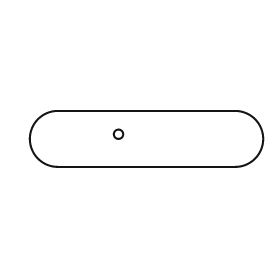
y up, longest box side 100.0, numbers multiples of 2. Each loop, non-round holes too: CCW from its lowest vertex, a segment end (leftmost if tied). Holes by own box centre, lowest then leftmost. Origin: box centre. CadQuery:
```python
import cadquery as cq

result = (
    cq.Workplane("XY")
    .moveTo(-38.0, -12.0)
    .lineTo(38.0, -12.0)
    .threePointArc((50.0, 0.0), (38.0, 12.0))
    .lineTo(-38.0, 12.0)
    .threePointArc((-50.0, 0.0), (-38.0, -12.0))
    .close()
    .moveTo(-12.0, 2.0)
    .circle(2.0)
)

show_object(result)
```